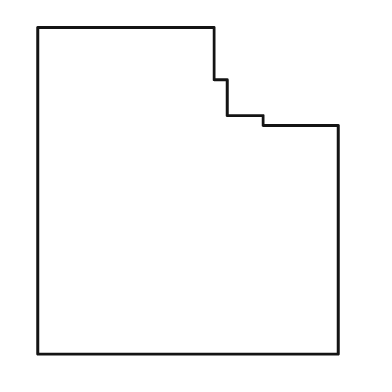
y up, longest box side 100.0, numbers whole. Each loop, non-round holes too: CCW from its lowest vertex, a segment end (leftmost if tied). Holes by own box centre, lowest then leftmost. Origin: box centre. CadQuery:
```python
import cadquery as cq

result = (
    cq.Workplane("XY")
    .moveTo(-46.0, -50.0)
    .lineTo(46.0, -50.0)
    .lineTo(46.0, 20.0)
    .lineTo(23.0, 20.0)
    .lineTo(23.0, 23.0)
    .lineTo(12.0, 23.0)
    .lineTo(12.0, 34.0)
    .lineTo(8.0, 34.0)
    .lineTo(8.0, 50.0)
    .lineTo(-46.0, 50.0)
    .close()
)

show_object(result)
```